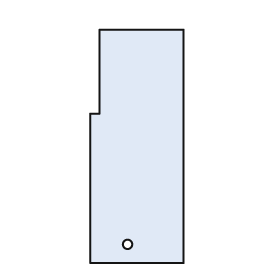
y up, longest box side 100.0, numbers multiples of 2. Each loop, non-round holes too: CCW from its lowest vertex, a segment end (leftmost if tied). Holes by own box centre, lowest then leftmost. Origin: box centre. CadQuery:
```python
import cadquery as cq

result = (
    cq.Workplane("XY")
    .moveTo(-20.0, -50.0)
    .lineTo(20.0, -50.0)
    .lineTo(20.0, 50.0)
    .lineTo(-16.0, 50.0)
    .lineTo(-16.0, 14.0)
    .lineTo(-20.0, 14.0)
    .close()
    .moveTo(-4.0, -42.0)
    .circle(2.0)
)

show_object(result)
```